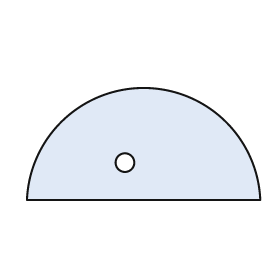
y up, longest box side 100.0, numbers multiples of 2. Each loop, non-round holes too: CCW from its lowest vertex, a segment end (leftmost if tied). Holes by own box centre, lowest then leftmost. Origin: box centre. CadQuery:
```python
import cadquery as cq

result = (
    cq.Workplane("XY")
    .moveTo(-50.0, -24.0)
    .lineTo(50.0, -24.0)
    .threePointArc((0.0, 24.0), (-50.0, -24.0))
    .close()
    .moveTo(-8.0, -8.0)
    .circle(4.0)
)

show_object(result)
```